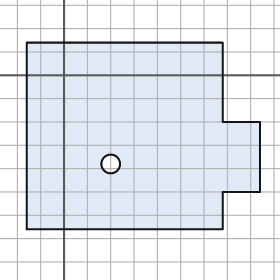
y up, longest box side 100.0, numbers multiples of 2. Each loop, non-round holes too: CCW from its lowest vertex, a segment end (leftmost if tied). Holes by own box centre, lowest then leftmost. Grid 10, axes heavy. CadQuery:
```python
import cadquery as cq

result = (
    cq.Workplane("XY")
    .moveTo(-16.0, -66.0)
    .lineTo(68.0, -66.0)
    .lineTo(68.0, -50.0)
    .lineTo(84.0, -50.0)
    .lineTo(84.0, -20.0)
    .lineTo(68.0, -20.0)
    .lineTo(68.0, 14.0)
    .lineTo(-16.0, 14.0)
    .close()
    .moveTo(20.0, -38.0)
    .circle(4.0)
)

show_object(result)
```